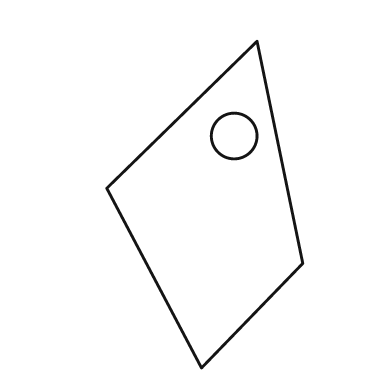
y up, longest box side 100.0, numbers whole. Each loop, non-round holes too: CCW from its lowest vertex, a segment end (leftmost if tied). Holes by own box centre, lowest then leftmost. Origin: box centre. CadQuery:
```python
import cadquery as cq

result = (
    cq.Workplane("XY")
    .moveTo(-1.0, -50.0)
    .lineTo(30.0, -18.0)
    .lineTo(16.0, 50.0)
    .lineTo(-30.0, 5.0)
    .close()
    .moveTo(9.0, 21.0)
    .circle(7.0)
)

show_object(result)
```